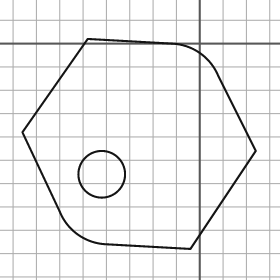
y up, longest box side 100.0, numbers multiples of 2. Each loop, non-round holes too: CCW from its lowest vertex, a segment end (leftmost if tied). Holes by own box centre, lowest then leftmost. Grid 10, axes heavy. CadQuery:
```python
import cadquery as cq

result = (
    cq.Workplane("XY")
    .moveTo(-4.0, -88.0)
    .lineTo(24.0, -46.0)
    .lineTo(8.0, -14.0)
    .threePointArc((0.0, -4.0), (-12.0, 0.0))
    .lineTo(-48.0, 2.0)
    .lineTo(-76.0, -38.0)
    .lineTo(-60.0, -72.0)
    .threePointArc((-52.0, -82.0), (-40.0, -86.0))
    .close()
    .moveTo(-42.0, -56.0)
    .circle(10.0)
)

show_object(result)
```